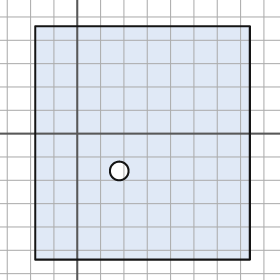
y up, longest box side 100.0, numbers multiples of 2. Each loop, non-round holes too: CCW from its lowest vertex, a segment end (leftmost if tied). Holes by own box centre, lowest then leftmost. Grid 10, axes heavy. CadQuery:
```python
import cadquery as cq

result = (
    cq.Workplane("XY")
    .moveTo(-18.0, -54.0)
    .lineTo(74.0, -54.0)
    .lineTo(74.0, 46.0)
    .lineTo(-18.0, 46.0)
    .close()
    .moveTo(18.0, -16.0)
    .circle(4.0)
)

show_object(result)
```